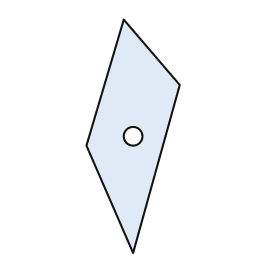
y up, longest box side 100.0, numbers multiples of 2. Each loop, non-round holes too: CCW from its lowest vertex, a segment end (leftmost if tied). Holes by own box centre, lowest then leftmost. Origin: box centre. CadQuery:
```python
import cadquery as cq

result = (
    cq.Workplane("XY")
    .moveTo(0.0, -50.0)
    .lineTo(20.0, 22.0)
    .lineTo(-4.0, 50.0)
    .lineTo(-20.0, -4.0)
    .close()
    .moveTo(0.0, 0.0)
    .circle(4.0)
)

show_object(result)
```